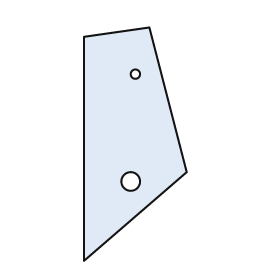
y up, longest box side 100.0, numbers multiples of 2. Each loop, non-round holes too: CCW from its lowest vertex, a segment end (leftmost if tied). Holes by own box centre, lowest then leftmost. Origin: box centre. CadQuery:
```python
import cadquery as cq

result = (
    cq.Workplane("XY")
    .moveTo(-22.0, -50.0)
    .lineTo(22.0, -12.0)
    .lineTo(6.0, 50.0)
    .lineTo(-22.0, 46.0)
    .close()
    .moveTo(-2.0, -16.0)
    .circle(4.0)
    .moveTo(0.0, 30.0)
    .circle(2.0)
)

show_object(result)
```